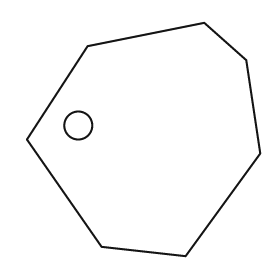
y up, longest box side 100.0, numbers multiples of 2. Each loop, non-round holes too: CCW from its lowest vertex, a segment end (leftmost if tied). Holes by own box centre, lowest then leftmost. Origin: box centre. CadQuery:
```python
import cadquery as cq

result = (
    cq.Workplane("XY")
    .moveTo(18.0, -50.0)
    .lineTo(50.0, -6.0)
    .lineTo(44.0, 34.0)
    .lineTo(26.0, 50.0)
    .lineTo(-24.0, 40.0)
    .lineTo(-50.0, 0.0)
    .lineTo(-18.0, -46.0)
    .close()
    .moveTo(-28.0, 6.0)
    .circle(6.0)
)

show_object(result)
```